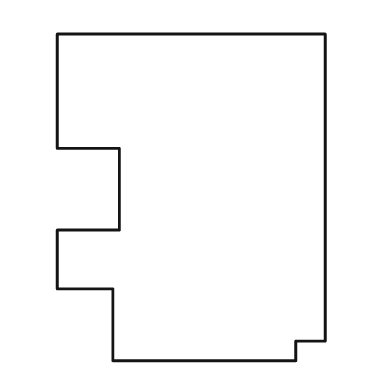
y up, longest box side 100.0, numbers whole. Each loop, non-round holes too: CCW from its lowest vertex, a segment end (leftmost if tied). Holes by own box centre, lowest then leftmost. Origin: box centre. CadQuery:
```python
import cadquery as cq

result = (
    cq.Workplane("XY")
    .moveTo(-24.0, -50.0)
    .lineTo(32.0, -50.0)
    .lineTo(32.0, -44.0)
    .lineTo(41.0, -44.0)
    .lineTo(41.0, 50.0)
    .lineTo(-41.0, 50.0)
    .lineTo(-41.0, 15.0)
    .lineTo(-22.0, 15.0)
    .lineTo(-22.0, -10.0)
    .lineTo(-41.0, -10.0)
    .lineTo(-41.0, -28.0)
    .lineTo(-24.0, -28.0)
    .close()
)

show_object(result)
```